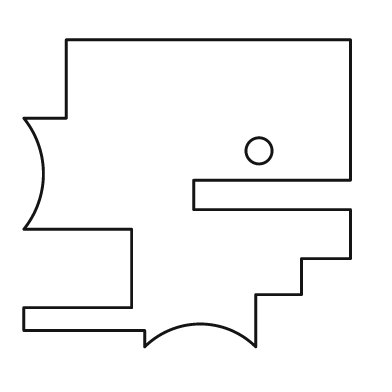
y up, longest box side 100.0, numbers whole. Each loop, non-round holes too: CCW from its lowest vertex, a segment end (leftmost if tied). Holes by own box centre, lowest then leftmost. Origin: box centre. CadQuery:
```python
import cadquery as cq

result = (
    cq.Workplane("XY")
    .moveTo(-13.0, -47.0)
    .threePointArc((4.0, -40.0), (21.0, -47.0))
    .lineTo(21.0, -31.0)
    .lineTo(35.0, -31.0)
    .lineTo(35.0, -20.0)
    .lineTo(50.0, -20.0)
    .lineTo(50.0, -5.0)
    .lineTo(2.0, -5.0)
    .lineTo(2.0, 4.0)
    .lineTo(50.0, 4.0)
    .lineTo(50.0, 47.0)
    .lineTo(-37.0, 47.0)
    .lineTo(-37.0, 23.0)
    .lineTo(-50.0, 23.0)
    .threePointArc((-44.0, 6.0), (-50.0, -11.0))
    .lineTo(-17.0, -11.0)
    .lineTo(-17.0, -35.0)
    .lineTo(-50.0, -35.0)
    .lineTo(-50.0, -42.0)
    .lineTo(-13.0, -42.0)
    .close()
    .moveTo(22.0, 13.0)
    .circle(4.0)
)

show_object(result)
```